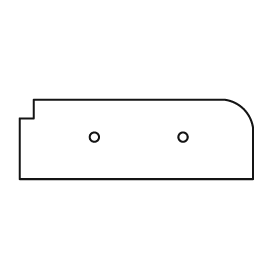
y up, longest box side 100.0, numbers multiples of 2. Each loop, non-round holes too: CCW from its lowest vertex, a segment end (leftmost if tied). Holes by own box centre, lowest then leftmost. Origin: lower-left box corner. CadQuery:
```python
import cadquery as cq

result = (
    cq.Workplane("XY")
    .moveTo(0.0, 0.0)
    .lineTo(100.0, 0.0)
    .lineTo(100.0, 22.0)
    .threePointArc((96.0, 30.0), (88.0, 34.0))
    .lineTo(6.0, 34.0)
    .lineTo(6.0, 26.0)
    .lineTo(0.0, 26.0)
    .close()
    .moveTo(32.0, 18.0)
    .circle(2.0)
    .moveTo(70.0, 18.0)
    .circle(2.0)
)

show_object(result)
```